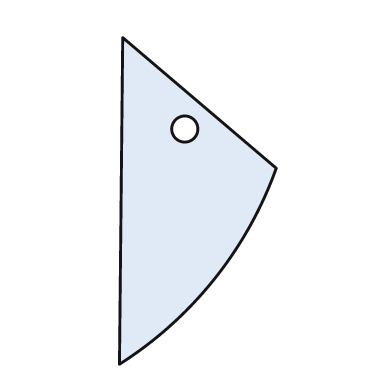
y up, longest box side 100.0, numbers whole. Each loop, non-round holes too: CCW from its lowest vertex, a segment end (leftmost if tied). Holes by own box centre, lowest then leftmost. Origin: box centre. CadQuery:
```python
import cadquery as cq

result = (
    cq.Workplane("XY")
    .moveTo(-24.0, -50.0)
    .threePointArc((5.0, -24.0), (24.0, 10.0))
    .lineTo(-23.0, 50.0)
    .close()
    .moveTo(-4.0, 22.0)
    .circle(4.0)
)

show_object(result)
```